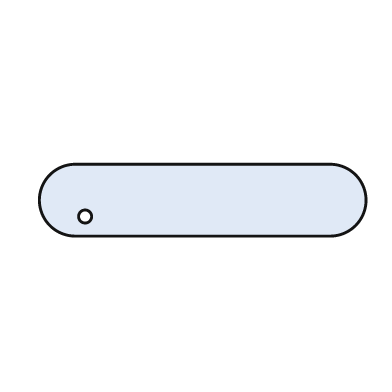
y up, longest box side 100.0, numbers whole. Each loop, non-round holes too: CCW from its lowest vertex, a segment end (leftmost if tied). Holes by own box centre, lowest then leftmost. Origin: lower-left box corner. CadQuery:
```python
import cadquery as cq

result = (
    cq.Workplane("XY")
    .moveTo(11.0, 0.0)
    .lineTo(89.0, 0.0)
    .threePointArc((100.0, 11.0), (89.0, 22.0))
    .lineTo(11.0, 22.0)
    .threePointArc((0.0, 11.0), (11.0, 0.0))
    .close()
    .moveTo(14.0, 6.0)
    .circle(2.0)
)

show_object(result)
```